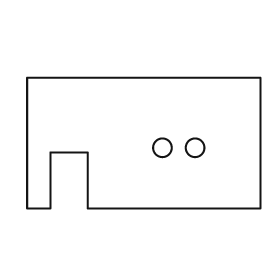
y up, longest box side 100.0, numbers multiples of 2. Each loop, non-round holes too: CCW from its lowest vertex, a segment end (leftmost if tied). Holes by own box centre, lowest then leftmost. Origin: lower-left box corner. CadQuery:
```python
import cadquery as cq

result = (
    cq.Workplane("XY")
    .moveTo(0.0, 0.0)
    .lineTo(10.0, 0.0)
    .lineTo(10.0, 24.0)
    .lineTo(26.0, 24.0)
    .lineTo(26.0, 0.0)
    .lineTo(100.0, 0.0)
    .lineTo(100.0, 56.0)
    .lineTo(0.0, 56.0)
    .close()
    .moveTo(58.0, 26.0)
    .circle(4.0)
    .moveTo(72.0, 26.0)
    .circle(4.0)
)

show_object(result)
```